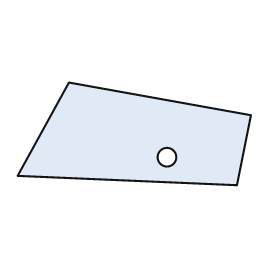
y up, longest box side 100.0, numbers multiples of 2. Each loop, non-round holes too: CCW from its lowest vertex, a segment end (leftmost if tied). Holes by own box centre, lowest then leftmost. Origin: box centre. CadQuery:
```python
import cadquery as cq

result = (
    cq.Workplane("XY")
    .moveTo(44.0, -22.0)
    .lineTo(50.0, 8.0)
    .lineTo(-28.0, 22.0)
    .lineTo(-50.0, -18.0)
    .close()
    .moveTo(14.0, -10.0)
    .circle(4.0)
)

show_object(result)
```